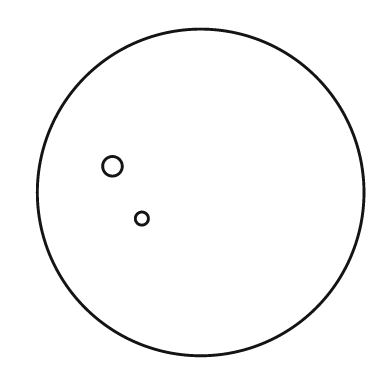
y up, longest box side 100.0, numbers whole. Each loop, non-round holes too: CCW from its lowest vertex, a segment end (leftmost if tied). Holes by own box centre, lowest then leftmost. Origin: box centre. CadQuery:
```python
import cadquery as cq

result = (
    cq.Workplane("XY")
    .moveTo(0.0, 0.0)
    .circle(50.0)
    .moveTo(-18.0, -8.0)
    .circle(2.0)
    .moveTo(-27.0, 8.0)
    .circle(3.0)
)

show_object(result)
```